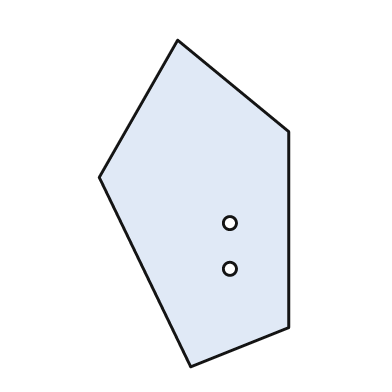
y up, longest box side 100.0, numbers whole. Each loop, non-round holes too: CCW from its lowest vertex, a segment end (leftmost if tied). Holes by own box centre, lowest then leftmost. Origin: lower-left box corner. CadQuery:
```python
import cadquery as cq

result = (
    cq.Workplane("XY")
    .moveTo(28.0, 0.0)
    .lineTo(58.0, 12.0)
    .lineTo(58.0, 72.0)
    .lineTo(24.0, 100.0)
    .lineTo(0.0, 58.0)
    .close()
    .moveTo(40.0, 30.0)
    .circle(2.0)
    .moveTo(40.0, 44.0)
    .circle(2.0)
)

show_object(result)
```